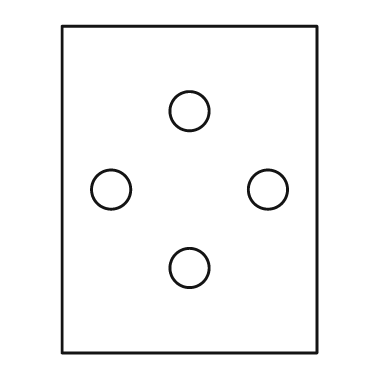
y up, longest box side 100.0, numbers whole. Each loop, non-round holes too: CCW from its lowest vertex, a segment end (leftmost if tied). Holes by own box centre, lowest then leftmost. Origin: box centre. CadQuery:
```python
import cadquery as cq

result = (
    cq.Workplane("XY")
    .moveTo(-39.0, -50.0)
    .lineTo(39.0, -50.0)
    .lineTo(39.0, 50.0)
    .lineTo(-39.0, 50.0)
    .close()
    .moveTo(0.0, -24.0)
    .circle(6.0)
    .moveTo(-24.0, 0.0)
    .circle(6.0)
    .moveTo(24.0, 0.0)
    .circle(6.0)
    .moveTo(0.0, 24.0)
    .circle(6.0)
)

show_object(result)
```